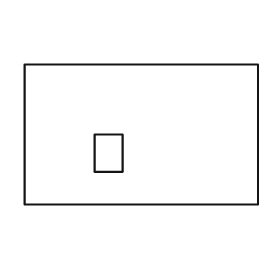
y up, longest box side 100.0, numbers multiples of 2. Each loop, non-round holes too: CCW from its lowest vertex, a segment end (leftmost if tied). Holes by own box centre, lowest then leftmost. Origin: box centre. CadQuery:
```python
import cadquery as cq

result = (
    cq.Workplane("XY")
    .moveTo(-50.0, -30.0)
    .lineTo(50.0, -30.0)
    .lineTo(50.0, 30.0)
    .lineTo(-50.0, 30.0)
    .close()
    .moveTo(-20.0, -16.0)
    .lineTo(-8.0, -16.0)
    .lineTo(-8.0, 0.0)
    .lineTo(-20.0, 0.0)
    .close()
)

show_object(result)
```